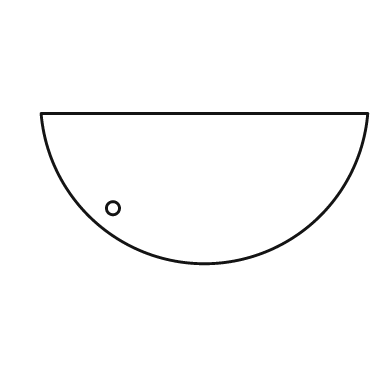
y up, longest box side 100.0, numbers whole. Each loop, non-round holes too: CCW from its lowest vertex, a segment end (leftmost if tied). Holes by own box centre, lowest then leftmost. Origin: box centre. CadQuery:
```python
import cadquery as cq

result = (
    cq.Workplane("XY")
    .moveTo(-50.0, 23.0)
    .threePointArc((0.0, -23.0), (50.0, 23.0))
    .close()
    .moveTo(-28.0, -6.0)
    .circle(2.0)
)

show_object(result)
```